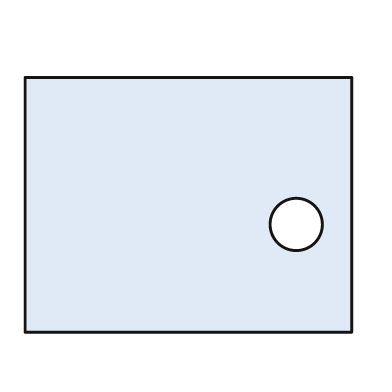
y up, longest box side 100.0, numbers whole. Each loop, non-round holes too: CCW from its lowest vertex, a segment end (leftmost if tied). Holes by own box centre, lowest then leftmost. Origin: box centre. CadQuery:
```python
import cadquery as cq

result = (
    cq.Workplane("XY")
    .moveTo(-50.0, -39.0)
    .lineTo(50.0, -39.0)
    .lineTo(50.0, 39.0)
    .lineTo(-50.0, 39.0)
    .close()
    .moveTo(33.0, -6.0)
    .circle(8.0)
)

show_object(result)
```